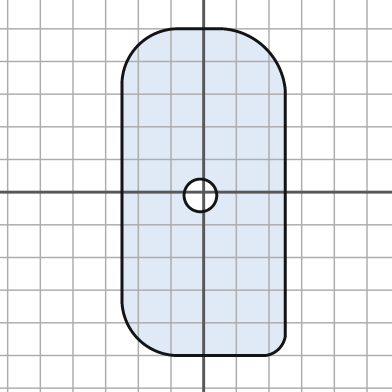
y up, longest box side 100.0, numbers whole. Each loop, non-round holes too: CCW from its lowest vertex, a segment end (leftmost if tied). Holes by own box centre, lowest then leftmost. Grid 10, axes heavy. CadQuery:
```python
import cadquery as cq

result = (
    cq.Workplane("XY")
    .moveTo(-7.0, -50.0)
    .lineTo(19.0, -50.0)
    .threePointArc((23.0, -48.0), (25.0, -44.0))
    .lineTo(25.0, 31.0)
    .threePointArc((19.0, 44.0), (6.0, 50.0))
    .lineTo(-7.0, 50.0)
    .threePointArc((-20.0, 45.0), (-25.0, 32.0))
    .lineTo(-25.0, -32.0)
    .threePointArc((-20.0, -45.0), (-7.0, -50.0))
    .close()
    .moveTo(-1.0, -1.0)
    .circle(5.0)
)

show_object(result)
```